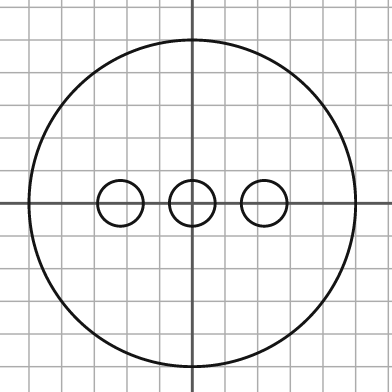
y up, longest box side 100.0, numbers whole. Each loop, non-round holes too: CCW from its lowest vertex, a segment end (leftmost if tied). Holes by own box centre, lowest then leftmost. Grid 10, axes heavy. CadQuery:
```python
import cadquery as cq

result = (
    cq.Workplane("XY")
    .moveTo(0.0, 0.0)
    .circle(50.0)
    .moveTo(-22.0, 0.0)
    .circle(7.0)
    .moveTo(0.0, 0.0)
    .circle(7.0)
    .moveTo(22.0, 0.0)
    .circle(7.0)
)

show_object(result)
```